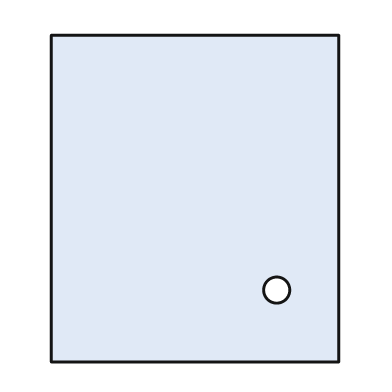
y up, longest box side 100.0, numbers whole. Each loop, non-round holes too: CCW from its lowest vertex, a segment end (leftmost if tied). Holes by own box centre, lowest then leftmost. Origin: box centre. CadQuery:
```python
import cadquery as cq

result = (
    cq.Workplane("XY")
    .moveTo(-44.0, -50.0)
    .lineTo(44.0, -50.0)
    .lineTo(44.0, 50.0)
    .lineTo(-44.0, 50.0)
    .close()
    .moveTo(25.0, -28.0)
    .circle(4.0)
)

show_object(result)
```